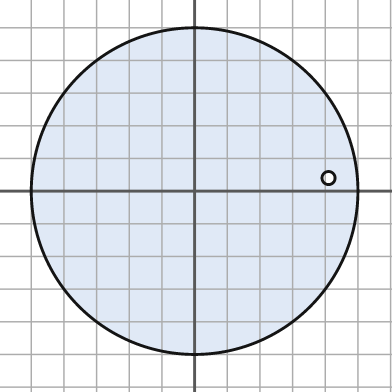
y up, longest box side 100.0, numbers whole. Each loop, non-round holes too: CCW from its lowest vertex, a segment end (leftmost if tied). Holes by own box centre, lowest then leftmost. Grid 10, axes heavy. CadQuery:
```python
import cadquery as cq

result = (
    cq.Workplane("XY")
    .moveTo(0.0, 0.0)
    .circle(50.0)
    .moveTo(41.0, 4.0)
    .circle(2.0)
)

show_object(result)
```